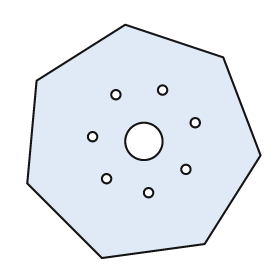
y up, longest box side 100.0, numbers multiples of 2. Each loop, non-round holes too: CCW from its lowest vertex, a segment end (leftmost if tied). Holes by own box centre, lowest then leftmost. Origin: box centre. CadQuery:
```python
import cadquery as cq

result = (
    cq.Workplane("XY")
    .moveTo(-18.0, -50.0)
    .lineTo(26.0, -44.0)
    .lineTo(50.0, -6.0)
    .lineTo(34.0, 36.0)
    .lineTo(-8.0, 50.0)
    .lineTo(-46.0, 26.0)
    .lineTo(-50.0, -18.0)
    .close()
    .moveTo(2.0, -22.0)
    .circle(2.0)
    .moveTo(-16.0, -16.0)
    .circle(2.0)
    .moveTo(18.0, -12.0)
    .circle(2.0)
    .moveTo(0.0, 0.0)
    .circle(8.0)
    .moveTo(-22.0, 2.0)
    .circle(2.0)
    .moveTo(22.0, 8.0)
    .circle(2.0)
    .moveTo(-12.0, 20.0)
    .circle(2.0)
    .moveTo(8.0, 22.0)
    .circle(2.0)
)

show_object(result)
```